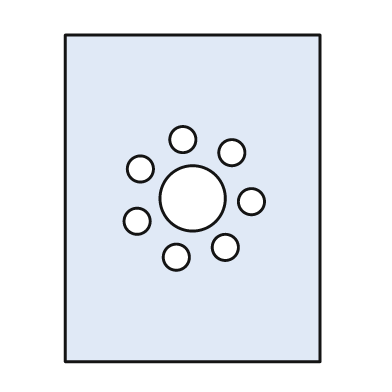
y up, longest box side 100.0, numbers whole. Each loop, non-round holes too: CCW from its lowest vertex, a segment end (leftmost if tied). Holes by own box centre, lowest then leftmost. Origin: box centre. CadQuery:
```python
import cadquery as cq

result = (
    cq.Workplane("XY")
    .moveTo(-39.0, -50.0)
    .lineTo(39.0, -50.0)
    .lineTo(39.0, 50.0)
    .lineTo(-39.0, 50.0)
    .close()
    .moveTo(-5.0, -18.0)
    .circle(4.0)
    .moveTo(10.0, -15.0)
    .circle(4.0)
    .moveTo(-17.0, -7.0)
    .circle(4.0)
    .moveTo(18.0, -1.0)
    .circle(4.0)
    .moveTo(0.0, 0.0)
    .circle(10.0)
    .moveTo(-16.0, 9.0)
    .circle(4.0)
    .moveTo(12.0, 14.0)
    .circle(4.0)
    .moveTo(-3.0, 18.0)
    .circle(4.0)
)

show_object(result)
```